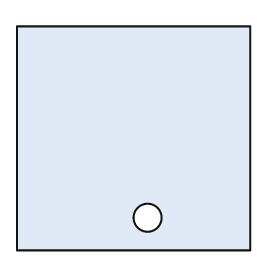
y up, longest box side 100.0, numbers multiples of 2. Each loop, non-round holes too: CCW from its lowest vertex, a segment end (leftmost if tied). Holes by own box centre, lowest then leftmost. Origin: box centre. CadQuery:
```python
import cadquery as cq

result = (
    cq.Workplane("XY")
    .moveTo(-50.0, -48.0)
    .lineTo(50.0, -48.0)
    .lineTo(50.0, 48.0)
    .lineTo(-50.0, 48.0)
    .close()
    .moveTo(6.0, -34.0)
    .circle(6.0)
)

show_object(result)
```